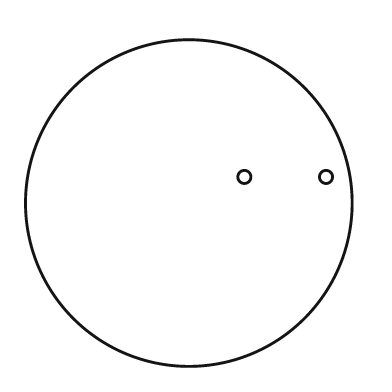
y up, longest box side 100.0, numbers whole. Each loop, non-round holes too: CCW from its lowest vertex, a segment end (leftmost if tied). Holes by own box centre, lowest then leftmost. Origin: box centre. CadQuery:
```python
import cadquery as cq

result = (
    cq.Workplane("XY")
    .moveTo(0.0, 0.0)
    .circle(50.0)
    .moveTo(17.0, 8.0)
    .circle(2.0)
    .moveTo(42.0, 8.0)
    .circle(2.0)
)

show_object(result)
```